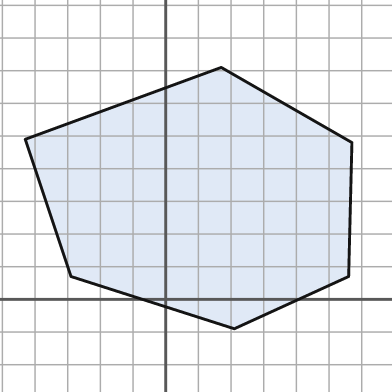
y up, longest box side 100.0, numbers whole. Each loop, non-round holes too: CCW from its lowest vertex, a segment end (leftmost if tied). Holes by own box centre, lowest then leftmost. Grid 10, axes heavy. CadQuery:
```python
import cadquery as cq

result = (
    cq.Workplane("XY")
    .moveTo(21.0, -9.0)
    .lineTo(56.0, 7.0)
    .lineTo(57.0, 48.0)
    .lineTo(17.0, 71.0)
    .lineTo(-43.0, 49.0)
    .lineTo(-29.0, 7.0)
    .close()
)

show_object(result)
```